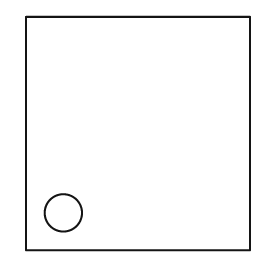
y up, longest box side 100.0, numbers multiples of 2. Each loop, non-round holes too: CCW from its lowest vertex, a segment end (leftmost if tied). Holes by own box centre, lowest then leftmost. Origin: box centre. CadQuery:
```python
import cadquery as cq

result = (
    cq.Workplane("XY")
    .moveTo(-48.0, -50.0)
    .lineTo(48.0, -50.0)
    .lineTo(48.0, 50.0)
    .lineTo(-48.0, 50.0)
    .close()
    .moveTo(-32.0, -34.0)
    .circle(8.0)
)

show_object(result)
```